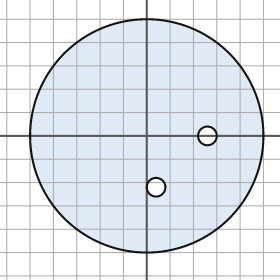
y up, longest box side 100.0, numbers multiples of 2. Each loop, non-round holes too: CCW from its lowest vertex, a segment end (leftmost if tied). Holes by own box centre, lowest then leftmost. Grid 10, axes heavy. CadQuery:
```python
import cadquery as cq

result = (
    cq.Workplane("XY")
    .moveTo(0.0, 0.0)
    .circle(50.0)
    .moveTo(4.0, -22.0)
    .circle(4.0)
    .moveTo(26.0, 0.0)
    .circle(4.0)
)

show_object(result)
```